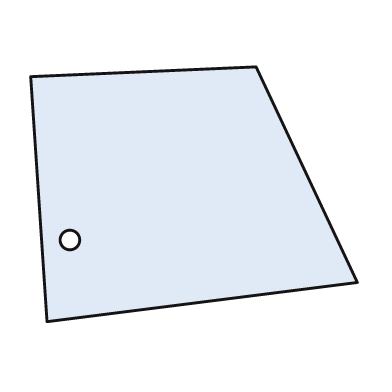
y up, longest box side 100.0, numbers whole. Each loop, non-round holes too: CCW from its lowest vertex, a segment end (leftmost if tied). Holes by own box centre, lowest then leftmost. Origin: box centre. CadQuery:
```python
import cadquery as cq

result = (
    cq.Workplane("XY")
    .moveTo(-45.0, -39.0)
    .lineTo(50.0, -27.0)
    .lineTo(19.0, 39.0)
    .lineTo(-50.0, 36.0)
    .close()
    .moveTo(-38.0, -14.0)
    .circle(3.0)
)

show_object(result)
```